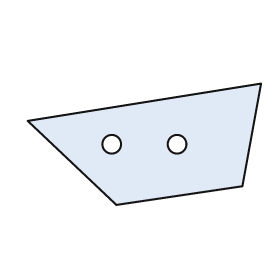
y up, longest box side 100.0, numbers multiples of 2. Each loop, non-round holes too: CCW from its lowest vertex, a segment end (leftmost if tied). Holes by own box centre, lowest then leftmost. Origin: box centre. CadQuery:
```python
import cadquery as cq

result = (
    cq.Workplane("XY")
    .moveTo(-12.0, -26.0)
    .lineTo(42.0, -18.0)
    .lineTo(50.0, 26.0)
    .lineTo(-50.0, 10.0)
    .close()
    .moveTo(-14.0, 0.0)
    .circle(4.0)
    .moveTo(14.0, 0.0)
    .circle(4.0)
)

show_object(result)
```